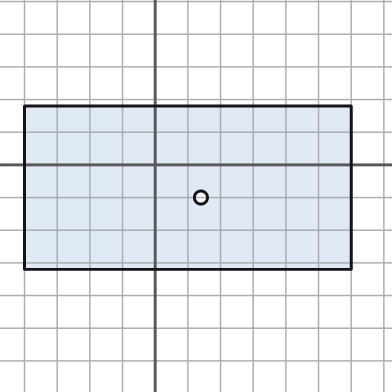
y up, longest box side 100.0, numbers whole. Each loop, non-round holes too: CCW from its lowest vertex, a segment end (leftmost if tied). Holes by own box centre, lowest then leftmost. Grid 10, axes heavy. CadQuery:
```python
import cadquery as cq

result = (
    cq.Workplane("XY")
    .moveTo(-40.0, -32.0)
    .lineTo(60.0, -32.0)
    .lineTo(60.0, 18.0)
    .lineTo(-40.0, 18.0)
    .close()
    .moveTo(14.0, -10.0)
    .circle(2.0)
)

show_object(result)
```